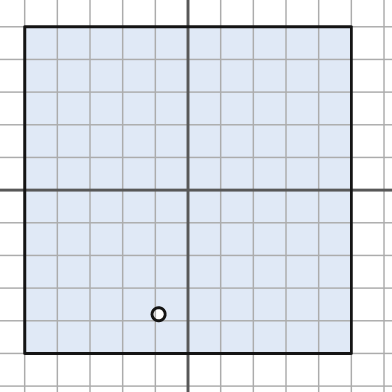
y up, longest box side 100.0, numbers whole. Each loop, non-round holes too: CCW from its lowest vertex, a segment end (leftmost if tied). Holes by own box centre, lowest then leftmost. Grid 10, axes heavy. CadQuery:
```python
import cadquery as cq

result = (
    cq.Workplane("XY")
    .moveTo(-50.0, -50.0)
    .lineTo(50.0, -50.0)
    .lineTo(50.0, 50.0)
    .lineTo(-50.0, 50.0)
    .close()
    .moveTo(-9.0, -38.0)
    .circle(2.0)
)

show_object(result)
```